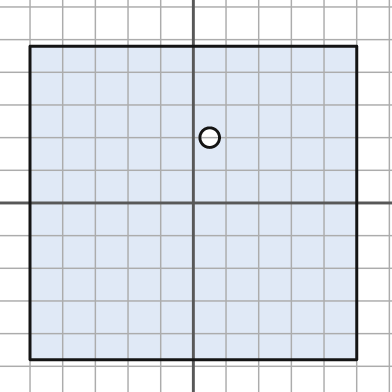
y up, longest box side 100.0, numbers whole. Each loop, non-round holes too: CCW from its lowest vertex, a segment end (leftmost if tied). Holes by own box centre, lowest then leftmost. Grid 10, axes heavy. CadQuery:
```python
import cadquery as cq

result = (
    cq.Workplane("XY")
    .moveTo(-50.0, -48.0)
    .lineTo(50.0, -48.0)
    .lineTo(50.0, 48.0)
    .lineTo(-50.0, 48.0)
    .close()
    .moveTo(5.0, 20.0)
    .circle(3.0)
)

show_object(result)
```